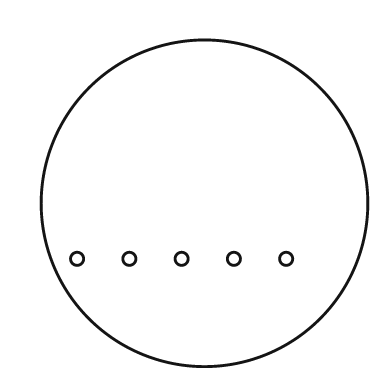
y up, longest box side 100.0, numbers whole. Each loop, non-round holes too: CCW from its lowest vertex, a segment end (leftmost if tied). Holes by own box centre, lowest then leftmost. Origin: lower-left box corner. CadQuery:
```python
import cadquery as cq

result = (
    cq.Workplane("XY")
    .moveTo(50.0, 50.0)
    .circle(50.0)
    .moveTo(11.0, 33.0)
    .circle(2.0)
    .moveTo(27.0, 33.0)
    .circle(2.0)
    .moveTo(43.0, 33.0)
    .circle(2.0)
    .moveTo(59.0, 33.0)
    .circle(2.0)
    .moveTo(75.0, 33.0)
    .circle(2.0)
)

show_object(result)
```